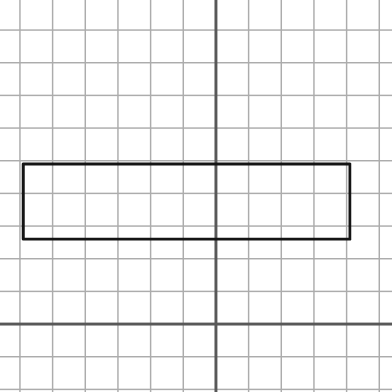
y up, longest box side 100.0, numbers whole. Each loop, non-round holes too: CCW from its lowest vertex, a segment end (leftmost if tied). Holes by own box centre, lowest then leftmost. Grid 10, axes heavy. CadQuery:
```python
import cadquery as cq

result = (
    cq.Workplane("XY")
    .moveTo(-59.0, 26.0)
    .lineTo(41.0, 26.0)
    .lineTo(41.0, 49.0)
    .lineTo(-59.0, 49.0)
    .close()
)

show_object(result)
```